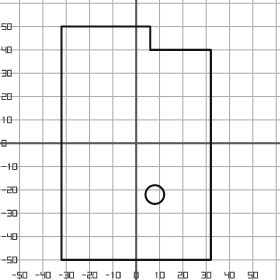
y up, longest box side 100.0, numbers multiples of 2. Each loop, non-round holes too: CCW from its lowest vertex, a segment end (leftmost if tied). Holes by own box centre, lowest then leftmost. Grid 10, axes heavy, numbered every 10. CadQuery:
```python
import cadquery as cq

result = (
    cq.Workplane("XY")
    .moveTo(-32.0, -50.0)
    .lineTo(32.0, -50.0)
    .lineTo(32.0, 40.0)
    .lineTo(6.0, 40.0)
    .lineTo(6.0, 50.0)
    .lineTo(-32.0, 50.0)
    .close()
    .moveTo(8.0, -22.0)
    .circle(4.0)
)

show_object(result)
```